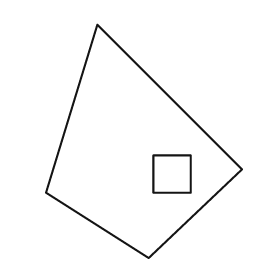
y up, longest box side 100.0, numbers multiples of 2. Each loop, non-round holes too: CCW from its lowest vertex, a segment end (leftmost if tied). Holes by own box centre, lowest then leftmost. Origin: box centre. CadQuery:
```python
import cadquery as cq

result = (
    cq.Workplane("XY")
    .moveTo(2.0, -50.0)
    .lineTo(42.0, -12.0)
    .lineTo(-20.0, 50.0)
    .lineTo(-42.0, -22.0)
    .close()
    .moveTo(4.0, -22.0)
    .lineTo(20.0, -22.0)
    .lineTo(20.0, -6.0)
    .lineTo(4.0, -6.0)
    .close()
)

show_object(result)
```